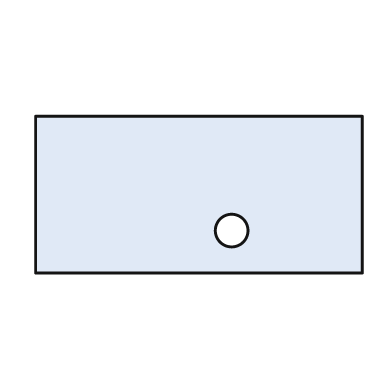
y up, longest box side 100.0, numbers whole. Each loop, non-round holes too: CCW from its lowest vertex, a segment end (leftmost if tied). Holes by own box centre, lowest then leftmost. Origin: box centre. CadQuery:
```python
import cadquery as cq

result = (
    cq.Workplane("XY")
    .moveTo(-50.0, -24.0)
    .lineTo(50.0, -24.0)
    .lineTo(50.0, 24.0)
    .lineTo(-50.0, 24.0)
    .close()
    .moveTo(10.0, -11.0)
    .circle(5.0)
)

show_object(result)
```